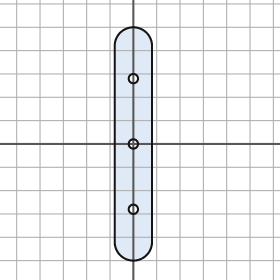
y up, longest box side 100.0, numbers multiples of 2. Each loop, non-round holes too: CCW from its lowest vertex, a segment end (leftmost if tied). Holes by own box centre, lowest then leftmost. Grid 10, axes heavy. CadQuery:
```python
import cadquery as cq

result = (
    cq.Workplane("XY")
    .moveTo(-8.0, -42.0)
    .threePointArc((0.0, -50.0), (8.0, -42.0))
    .lineTo(8.0, 42.0)
    .threePointArc((0.0, 50.0), (-8.0, 42.0))
    .close()
    .moveTo(0.0, -28.0)
    .circle(2.0)
    .moveTo(0.0, 0.0)
    .circle(2.0)
    .moveTo(0.0, 28.0)
    .circle(2.0)
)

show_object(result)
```